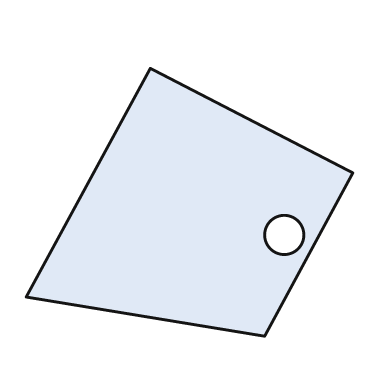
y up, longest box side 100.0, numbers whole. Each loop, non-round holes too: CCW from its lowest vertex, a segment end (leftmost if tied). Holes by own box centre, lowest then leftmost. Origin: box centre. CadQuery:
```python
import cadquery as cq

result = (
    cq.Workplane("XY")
    .moveTo(23.0, -41.0)
    .lineTo(50.0, 9.0)
    .lineTo(-12.0, 41.0)
    .lineTo(-50.0, -29.0)
    .close()
    .moveTo(29.0, -10.0)
    .circle(6.0)
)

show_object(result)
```